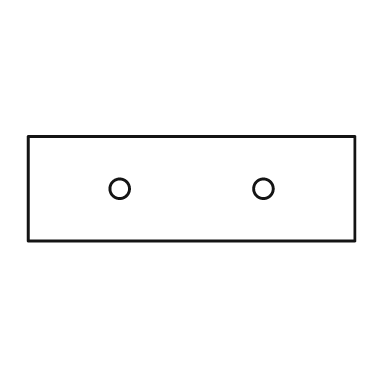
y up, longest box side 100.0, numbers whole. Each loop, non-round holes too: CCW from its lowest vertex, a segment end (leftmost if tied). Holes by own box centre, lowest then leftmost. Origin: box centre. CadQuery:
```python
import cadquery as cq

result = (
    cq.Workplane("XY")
    .moveTo(-50.0, -16.0)
    .lineTo(50.0, -16.0)
    .lineTo(50.0, 16.0)
    .lineTo(-50.0, 16.0)
    .close()
    .moveTo(-22.0, 0.0)
    .circle(3.0)
    .moveTo(22.0, 0.0)
    .circle(3.0)
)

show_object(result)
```